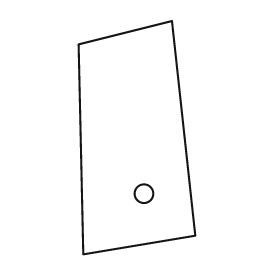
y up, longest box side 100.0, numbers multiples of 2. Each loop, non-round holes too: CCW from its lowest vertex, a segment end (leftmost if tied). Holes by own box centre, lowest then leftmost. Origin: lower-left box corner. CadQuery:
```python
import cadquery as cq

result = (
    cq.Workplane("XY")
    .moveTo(2.0, 0.0)
    .lineTo(50.0, 8.0)
    .lineTo(40.0, 100.0)
    .lineTo(0.0, 90.0)
    .close()
    .moveTo(28.0, 26.0)
    .circle(4.0)
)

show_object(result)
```